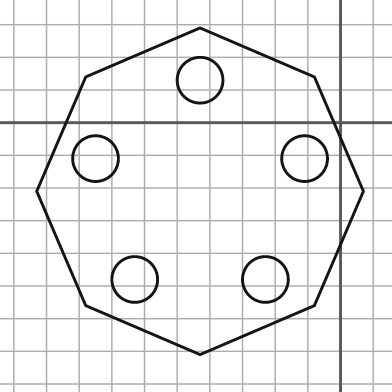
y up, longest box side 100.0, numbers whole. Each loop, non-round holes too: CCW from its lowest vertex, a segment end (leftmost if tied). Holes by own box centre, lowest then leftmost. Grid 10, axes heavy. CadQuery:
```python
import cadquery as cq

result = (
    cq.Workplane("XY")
    .moveTo(-43.0, -71.0)
    .lineTo(-8.0, -56.0)
    .lineTo(7.0, -21.0)
    .lineTo(-8.0, 14.0)
    .lineTo(-43.0, 29.0)
    .lineTo(-78.0, 14.0)
    .lineTo(-93.0, -21.0)
    .lineTo(-78.0, -56.0)
    .close()
    .moveTo(-63.0, -48.0)
    .circle(7.0)
    .moveTo(-23.0, -48.0)
    .circle(7.0)
    .moveTo(-75.0, -11.0)
    .circle(7.0)
    .moveTo(-11.0, -11.0)
    .circle(7.0)
    .moveTo(-43.0, 13.0)
    .circle(7.0)
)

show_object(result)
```